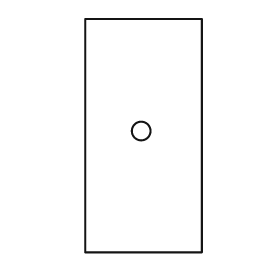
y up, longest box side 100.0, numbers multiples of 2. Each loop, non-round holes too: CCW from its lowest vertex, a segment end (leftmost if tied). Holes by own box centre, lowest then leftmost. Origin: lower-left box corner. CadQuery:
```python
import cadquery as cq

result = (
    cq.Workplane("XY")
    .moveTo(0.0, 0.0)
    .lineTo(50.0, 0.0)
    .lineTo(50.0, 100.0)
    .lineTo(0.0, 100.0)
    .close()
    .moveTo(24.0, 52.0)
    .circle(4.0)
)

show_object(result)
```